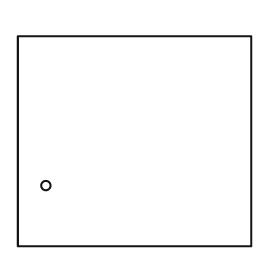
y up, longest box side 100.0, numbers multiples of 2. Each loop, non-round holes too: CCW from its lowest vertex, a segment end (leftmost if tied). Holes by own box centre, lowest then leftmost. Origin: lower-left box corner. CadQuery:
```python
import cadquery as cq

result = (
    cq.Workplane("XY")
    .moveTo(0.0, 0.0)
    .lineTo(100.0, 0.0)
    .lineTo(100.0, 90.0)
    .lineTo(0.0, 90.0)
    .close()
    .moveTo(12.0, 26.0)
    .circle(2.0)
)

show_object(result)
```